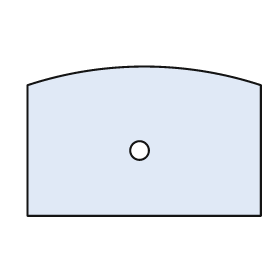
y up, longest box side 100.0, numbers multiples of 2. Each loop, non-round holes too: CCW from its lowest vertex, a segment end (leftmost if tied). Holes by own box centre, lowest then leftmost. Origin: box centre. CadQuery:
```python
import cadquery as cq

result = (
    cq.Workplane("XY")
    .moveTo(-50.0, -32.0)
    .lineTo(50.0, -32.0)
    .lineTo(50.0, 24.0)
    .threePointArc((0.0, 32.0), (-50.0, 24.0))
    .close()
    .moveTo(-2.0, -4.0)
    .circle(4.0)
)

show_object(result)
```